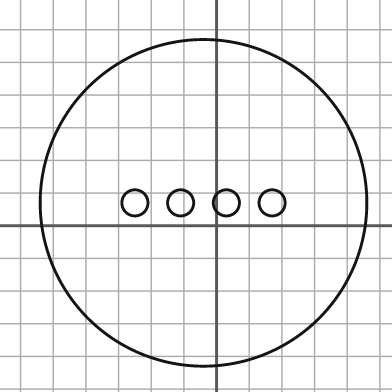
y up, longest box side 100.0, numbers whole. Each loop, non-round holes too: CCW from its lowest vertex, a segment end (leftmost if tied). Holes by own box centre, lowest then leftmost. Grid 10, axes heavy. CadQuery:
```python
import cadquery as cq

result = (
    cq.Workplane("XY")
    .moveTo(-4.0, 7.0)
    .circle(50.0)
    .moveTo(-25.0, 7.0)
    .circle(4.0)
    .moveTo(-11.0, 7.0)
    .circle(4.0)
    .moveTo(3.0, 7.0)
    .circle(4.0)
    .moveTo(17.0, 7.0)
    .circle(4.0)
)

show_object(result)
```